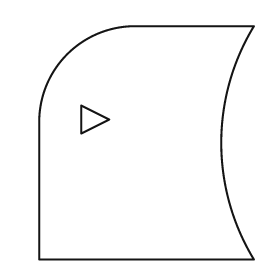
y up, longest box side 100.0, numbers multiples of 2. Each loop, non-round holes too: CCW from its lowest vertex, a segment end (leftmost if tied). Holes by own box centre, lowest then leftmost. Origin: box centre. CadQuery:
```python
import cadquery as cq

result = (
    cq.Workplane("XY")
    .moveTo(-46.0, -50.0)
    .lineTo(46.0, -50.0)
    .threePointArc((32.0, 0.0), (46.0, 50.0))
    .lineTo(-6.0, 50.0)
    .threePointArc((-34.0, 38.0), (-46.0, 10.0))
    .close()
    .moveTo(-28.0, 4.0)
    .lineTo(-16.0, 10.0)
    .lineTo(-28.0, 16.0)
    .close()
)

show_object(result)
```